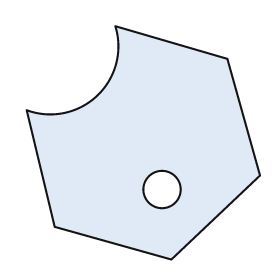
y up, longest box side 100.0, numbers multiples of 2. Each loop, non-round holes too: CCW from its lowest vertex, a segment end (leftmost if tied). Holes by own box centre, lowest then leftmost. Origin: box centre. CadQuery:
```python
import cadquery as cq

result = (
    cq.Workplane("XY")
    .moveTo(12.0, -50.0)
    .lineTo(50.0, -14.0)
    .lineTo(36.0, 36.0)
    .lineTo(-12.0, 50.0)
    .threePointArc((-20.0, 20.0), (-50.0, 14.0))
    .lineTo(-38.0, -36.0)
    .close()
    .moveTo(8.0, -20.0)
    .circle(8.0)
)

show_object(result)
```